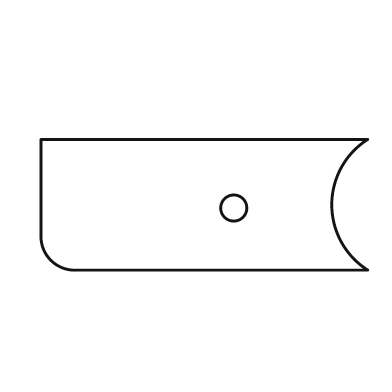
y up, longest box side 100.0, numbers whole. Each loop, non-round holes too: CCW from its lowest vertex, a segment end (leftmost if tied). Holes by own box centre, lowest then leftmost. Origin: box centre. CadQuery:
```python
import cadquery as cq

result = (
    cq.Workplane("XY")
    .moveTo(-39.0, -20.0)
    .lineTo(50.0, -20.0)
    .threePointArc((39.0, 0.0), (50.0, 20.0))
    .lineTo(-50.0, 20.0)
    .lineTo(-50.0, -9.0)
    .threePointArc((-47.0, -17.0), (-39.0, -20.0))
    .close()
    .moveTo(9.0, -1.0)
    .circle(4.0)
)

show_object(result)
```